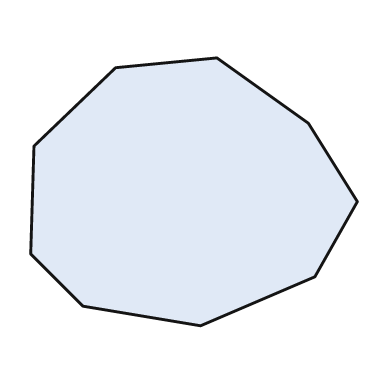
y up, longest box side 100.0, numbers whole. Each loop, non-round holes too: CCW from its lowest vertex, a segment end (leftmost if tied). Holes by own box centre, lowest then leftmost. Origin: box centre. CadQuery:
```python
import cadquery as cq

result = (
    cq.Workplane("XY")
    .moveTo(2.0, -41.0)
    .lineTo(37.0, -26.0)
    .lineTo(50.0, -3.0)
    .lineTo(35.0, 21.0)
    .lineTo(7.0, 41.0)
    .lineTo(-24.0, 38.0)
    .lineTo(-49.0, 14.0)
    .lineTo(-50.0, -19.0)
    .lineTo(-34.0, -35.0)
    .close()
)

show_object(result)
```